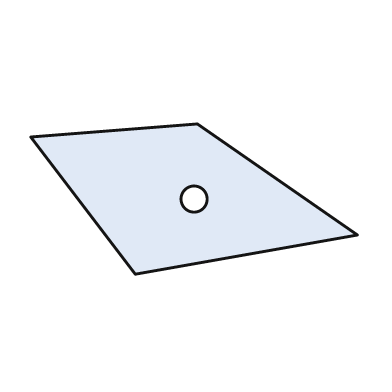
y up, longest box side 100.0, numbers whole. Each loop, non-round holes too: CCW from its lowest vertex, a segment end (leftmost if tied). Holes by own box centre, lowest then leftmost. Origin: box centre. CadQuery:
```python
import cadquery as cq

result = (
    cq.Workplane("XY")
    .moveTo(-18.0, -23.0)
    .lineTo(50.0, -11.0)
    .lineTo(1.0, 23.0)
    .lineTo(-50.0, 19.0)
    .close()
    .moveTo(0.0, 0.0)
    .circle(4.0)
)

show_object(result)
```